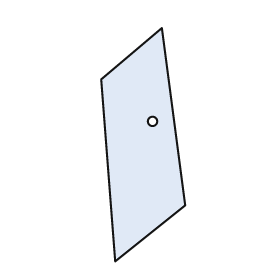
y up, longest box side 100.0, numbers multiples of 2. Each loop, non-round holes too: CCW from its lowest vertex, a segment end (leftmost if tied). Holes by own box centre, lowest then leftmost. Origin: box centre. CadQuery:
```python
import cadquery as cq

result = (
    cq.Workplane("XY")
    .moveTo(-12.0, -50.0)
    .lineTo(18.0, -26.0)
    .lineTo(8.0, 50.0)
    .lineTo(-18.0, 28.0)
    .close()
    .moveTo(4.0, 10.0)
    .circle(2.0)
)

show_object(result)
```